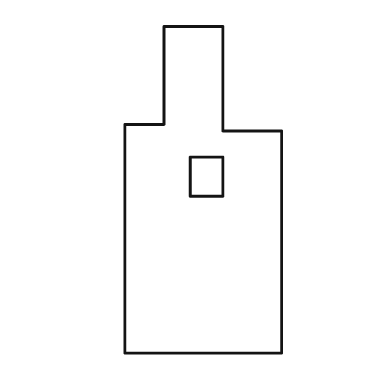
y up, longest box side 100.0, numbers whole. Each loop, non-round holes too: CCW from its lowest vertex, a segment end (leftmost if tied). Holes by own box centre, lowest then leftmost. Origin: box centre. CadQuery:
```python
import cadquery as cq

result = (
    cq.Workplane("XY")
    .moveTo(-24.0, -50.0)
    .lineTo(24.0, -50.0)
    .lineTo(24.0, 18.0)
    .lineTo(6.0, 18.0)
    .lineTo(6.0, 50.0)
    .lineTo(-12.0, 50.0)
    .lineTo(-12.0, 20.0)
    .lineTo(-24.0, 20.0)
    .close()
    .moveTo(-4.0, -2.0)
    .lineTo(6.0, -2.0)
    .lineTo(6.0, 10.0)
    .lineTo(-4.0, 10.0)
    .close()
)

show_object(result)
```